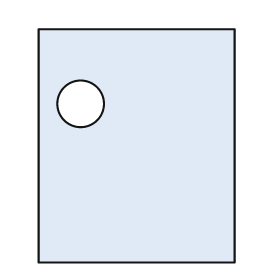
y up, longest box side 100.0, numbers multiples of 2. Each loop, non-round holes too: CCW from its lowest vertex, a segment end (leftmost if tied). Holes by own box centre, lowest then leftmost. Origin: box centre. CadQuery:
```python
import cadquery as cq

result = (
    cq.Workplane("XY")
    .moveTo(-42.0, -50.0)
    .lineTo(42.0, -50.0)
    .lineTo(42.0, 50.0)
    .lineTo(-42.0, 50.0)
    .close()
    .moveTo(-24.0, 18.0)
    .circle(10.0)
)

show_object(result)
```